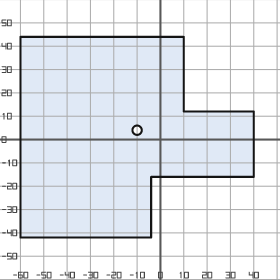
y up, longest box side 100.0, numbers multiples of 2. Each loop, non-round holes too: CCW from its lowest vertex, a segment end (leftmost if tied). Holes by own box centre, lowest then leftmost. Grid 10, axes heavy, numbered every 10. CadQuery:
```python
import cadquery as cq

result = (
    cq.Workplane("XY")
    .moveTo(-60.0, -42.0)
    .lineTo(-4.0, -42.0)
    .lineTo(-4.0, -16.0)
    .lineTo(40.0, -16.0)
    .lineTo(40.0, 12.0)
    .lineTo(10.0, 12.0)
    .lineTo(10.0, 44.0)
    .lineTo(-60.0, 44.0)
    .close()
    .moveTo(-10.0, 4.0)
    .circle(2.0)
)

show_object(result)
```